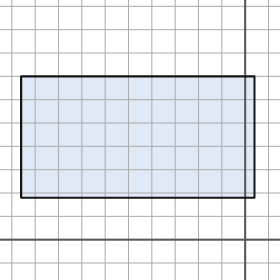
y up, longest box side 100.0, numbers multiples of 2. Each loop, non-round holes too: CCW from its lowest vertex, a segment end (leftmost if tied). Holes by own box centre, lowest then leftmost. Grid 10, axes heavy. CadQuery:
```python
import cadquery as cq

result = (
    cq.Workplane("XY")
    .moveTo(-96.0, 18.0)
    .lineTo(4.0, 18.0)
    .lineTo(4.0, 70.0)
    .lineTo(-96.0, 70.0)
    .close()
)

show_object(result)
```